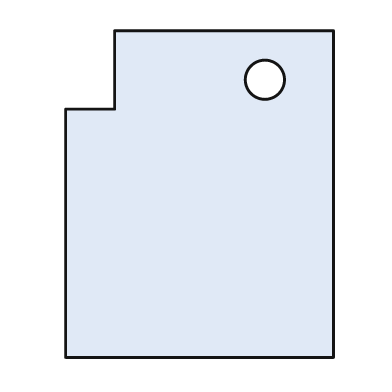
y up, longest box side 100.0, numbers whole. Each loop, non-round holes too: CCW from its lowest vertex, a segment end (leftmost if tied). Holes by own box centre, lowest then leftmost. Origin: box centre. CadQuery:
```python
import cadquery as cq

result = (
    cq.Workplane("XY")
    .moveTo(-41.0, -50.0)
    .lineTo(41.0, -50.0)
    .lineTo(41.0, 50.0)
    .lineTo(-26.0, 50.0)
    .lineTo(-26.0, 26.0)
    .lineTo(-41.0, 26.0)
    .close()
    .moveTo(20.0, 35.0)
    .circle(6.0)
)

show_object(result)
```